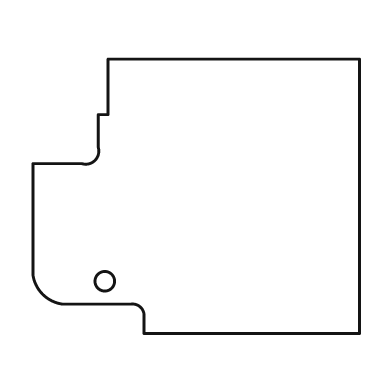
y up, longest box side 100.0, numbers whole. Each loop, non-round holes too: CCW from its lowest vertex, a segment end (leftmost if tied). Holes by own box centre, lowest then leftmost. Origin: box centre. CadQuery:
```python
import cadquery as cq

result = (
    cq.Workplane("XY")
    .moveTo(-16.0, -42.0)
    .lineTo(50.0, -42.0)
    .lineTo(50.0, 42.0)
    .lineTo(-27.0, 42.0)
    .lineTo(-27.0, 25.0)
    .lineTo(-30.0, 25.0)
    .lineTo(-30.0, 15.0)
    .threePointArc((-31.0, 11.0), (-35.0, 10.0))
    .lineTo(-50.0, 10.0)
    .lineTo(-50.0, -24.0)
    .threePointArc((-47.0, -30.0), (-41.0, -33.0))
    .lineTo(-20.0, -33.0)
    .threePointArc((-17.0, -34.0), (-16.0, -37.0))
    .close()
    .moveTo(-28.0, -26.0)
    .circle(3.0)
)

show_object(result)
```